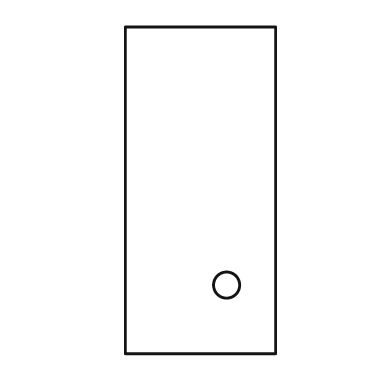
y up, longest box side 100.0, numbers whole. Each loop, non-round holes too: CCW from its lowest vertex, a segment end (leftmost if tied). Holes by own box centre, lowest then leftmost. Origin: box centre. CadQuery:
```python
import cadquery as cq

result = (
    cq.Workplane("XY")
    .moveTo(-23.0, -50.0)
    .lineTo(23.0, -50.0)
    .lineTo(23.0, 50.0)
    .lineTo(-23.0, 50.0)
    .close()
    .moveTo(8.0, -29.0)
    .circle(4.0)
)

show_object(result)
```